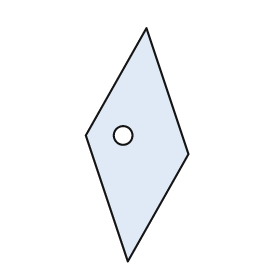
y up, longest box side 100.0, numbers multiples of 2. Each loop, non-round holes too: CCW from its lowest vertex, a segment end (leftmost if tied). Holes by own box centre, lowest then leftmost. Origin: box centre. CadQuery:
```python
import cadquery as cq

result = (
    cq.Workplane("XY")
    .moveTo(-4.0, -50.0)
    .lineTo(22.0, -4.0)
    .lineTo(4.0, 50.0)
    .lineTo(-22.0, 4.0)
    .close()
    .moveTo(-6.0, 4.0)
    .circle(4.0)
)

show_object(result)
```